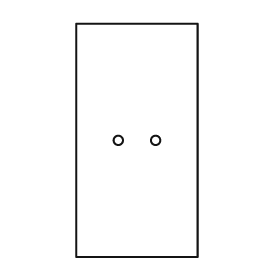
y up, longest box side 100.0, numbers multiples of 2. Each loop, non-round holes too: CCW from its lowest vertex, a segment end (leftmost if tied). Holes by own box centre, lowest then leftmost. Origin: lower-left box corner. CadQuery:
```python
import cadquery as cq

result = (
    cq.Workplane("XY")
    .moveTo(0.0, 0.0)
    .lineTo(52.0, 0.0)
    .lineTo(52.0, 100.0)
    .lineTo(0.0, 100.0)
    .close()
    .moveTo(18.0, 50.0)
    .circle(2.0)
    .moveTo(34.0, 50.0)
    .circle(2.0)
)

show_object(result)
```